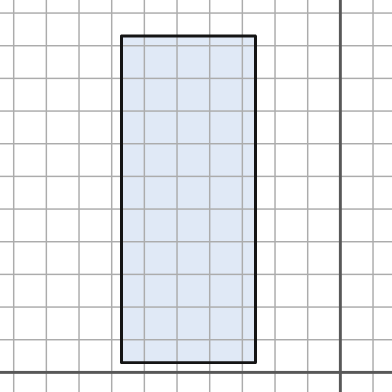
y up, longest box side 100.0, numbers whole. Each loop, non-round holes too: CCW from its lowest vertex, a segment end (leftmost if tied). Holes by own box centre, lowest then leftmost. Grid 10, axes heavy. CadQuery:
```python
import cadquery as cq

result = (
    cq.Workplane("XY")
    .moveTo(-67.0, 3.0)
    .lineTo(-26.0, 3.0)
    .lineTo(-26.0, 103.0)
    .lineTo(-67.0, 103.0)
    .close()
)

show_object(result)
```